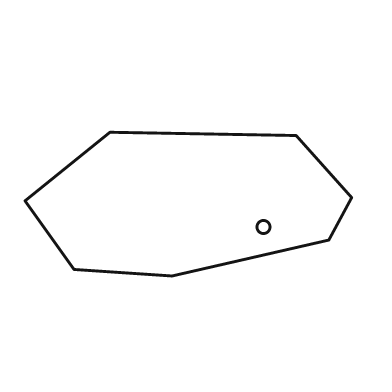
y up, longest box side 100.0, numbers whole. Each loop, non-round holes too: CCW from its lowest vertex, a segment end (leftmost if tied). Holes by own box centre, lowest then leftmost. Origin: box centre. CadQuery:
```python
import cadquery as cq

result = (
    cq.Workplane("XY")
    .moveTo(-5.0, -22.0)
    .lineTo(43.0, -11.0)
    .lineTo(50.0, 2.0)
    .lineTo(33.0, 21.0)
    .lineTo(-24.0, 22.0)
    .lineTo(-50.0, 1.0)
    .lineTo(-35.0, -20.0)
    .close()
    .moveTo(23.0, -7.0)
    .circle(2.0)
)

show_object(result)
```